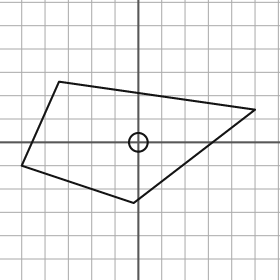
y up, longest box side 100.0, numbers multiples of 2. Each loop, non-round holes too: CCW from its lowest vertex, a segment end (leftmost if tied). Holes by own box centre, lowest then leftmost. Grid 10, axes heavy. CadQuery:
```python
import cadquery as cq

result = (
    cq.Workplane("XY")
    .moveTo(-2.0, -26.0)
    .lineTo(50.0, 14.0)
    .lineTo(-34.0, 26.0)
    .lineTo(-50.0, -10.0)
    .close()
    .moveTo(0.0, 0.0)
    .circle(4.0)
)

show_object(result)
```